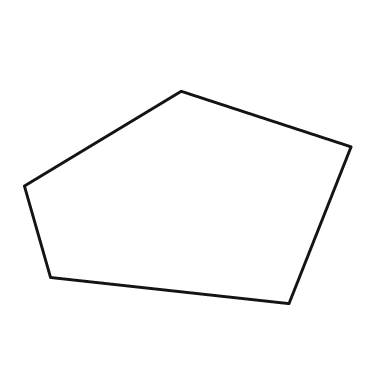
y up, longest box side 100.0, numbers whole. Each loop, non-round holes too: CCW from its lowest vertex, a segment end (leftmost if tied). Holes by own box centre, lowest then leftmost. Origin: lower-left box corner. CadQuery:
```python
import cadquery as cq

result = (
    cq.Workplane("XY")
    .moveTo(81.0, 0.0)
    .lineTo(100.0, 48.0)
    .lineTo(48.0, 65.0)
    .lineTo(0.0, 36.0)
    .lineTo(8.0, 8.0)
    .close()
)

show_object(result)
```